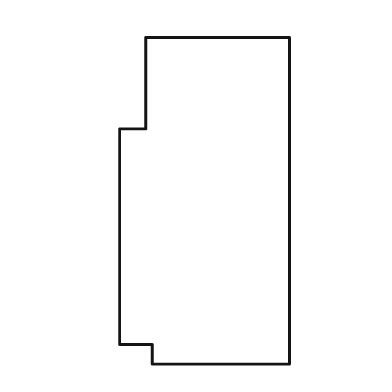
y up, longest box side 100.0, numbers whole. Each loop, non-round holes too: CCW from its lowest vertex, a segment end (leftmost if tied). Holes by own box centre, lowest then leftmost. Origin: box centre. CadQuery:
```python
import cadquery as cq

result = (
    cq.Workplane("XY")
    .moveTo(-16.0, -50.0)
    .lineTo(26.0, -50.0)
    .lineTo(26.0, 50.0)
    .lineTo(-18.0, 50.0)
    .lineTo(-18.0, 22.0)
    .lineTo(-26.0, 22.0)
    .lineTo(-26.0, -44.0)
    .lineTo(-16.0, -44.0)
    .close()
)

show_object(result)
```